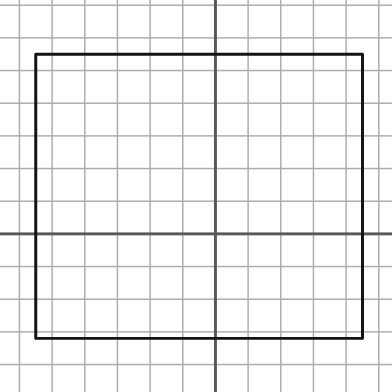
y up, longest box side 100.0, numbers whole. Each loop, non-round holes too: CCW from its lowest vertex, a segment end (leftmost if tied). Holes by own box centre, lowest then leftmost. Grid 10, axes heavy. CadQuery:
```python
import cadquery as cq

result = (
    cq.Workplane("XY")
    .moveTo(-55.0, -32.0)
    .lineTo(45.0, -32.0)
    .lineTo(45.0, 55.0)
    .lineTo(-55.0, 55.0)
    .close()
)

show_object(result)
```